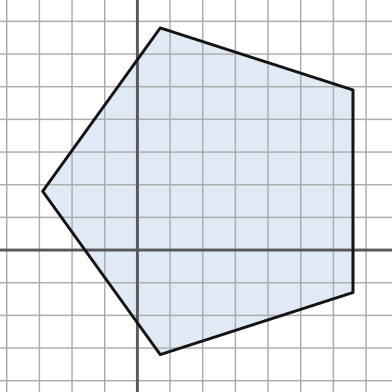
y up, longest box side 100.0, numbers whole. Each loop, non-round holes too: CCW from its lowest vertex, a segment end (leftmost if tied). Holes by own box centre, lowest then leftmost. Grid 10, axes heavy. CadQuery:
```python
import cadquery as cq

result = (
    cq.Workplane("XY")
    .moveTo(7.0, -32.0)
    .lineTo(66.0, -13.0)
    .lineTo(66.0, 49.0)
    .lineTo(7.0, 68.0)
    .lineTo(-29.0, 18.0)
    .close()
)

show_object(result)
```